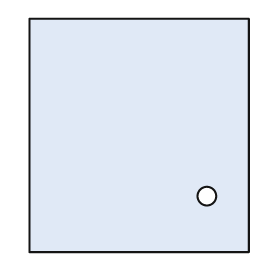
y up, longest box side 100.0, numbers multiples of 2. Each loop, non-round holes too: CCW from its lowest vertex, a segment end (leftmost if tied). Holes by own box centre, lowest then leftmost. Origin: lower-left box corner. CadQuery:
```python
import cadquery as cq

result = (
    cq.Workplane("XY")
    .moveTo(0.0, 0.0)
    .lineTo(94.0, 0.0)
    .lineTo(94.0, 100.0)
    .lineTo(0.0, 100.0)
    .close()
    .moveTo(76.0, 24.0)
    .circle(4.0)
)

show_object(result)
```